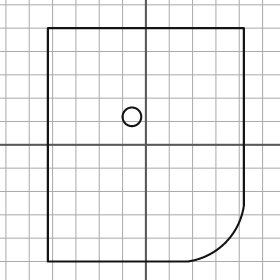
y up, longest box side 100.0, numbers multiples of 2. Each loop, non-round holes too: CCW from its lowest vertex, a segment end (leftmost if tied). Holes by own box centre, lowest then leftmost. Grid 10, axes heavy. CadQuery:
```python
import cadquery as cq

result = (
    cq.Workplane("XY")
    .moveTo(-42.0, -50.0)
    .lineTo(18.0, -50.0)
    .threePointArc((34.0, -42.0), (42.0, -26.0))
    .lineTo(42.0, 50.0)
    .lineTo(-42.0, 50.0)
    .close()
    .moveTo(-6.0, 12.0)
    .circle(4.0)
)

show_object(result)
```